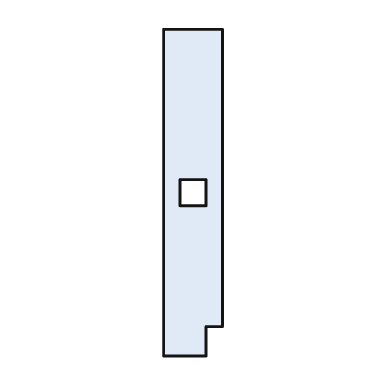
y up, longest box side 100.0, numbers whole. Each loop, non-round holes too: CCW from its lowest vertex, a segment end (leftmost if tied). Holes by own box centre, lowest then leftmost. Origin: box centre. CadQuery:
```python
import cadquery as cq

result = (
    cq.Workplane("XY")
    .moveTo(-9.0, -50.0)
    .lineTo(4.0, -50.0)
    .lineTo(4.0, -41.0)
    .lineTo(9.0, -41.0)
    .lineTo(9.0, 50.0)
    .lineTo(-9.0, 50.0)
    .close()
    .moveTo(-4.0, -4.0)
    .lineTo(4.0, -4.0)
    .lineTo(4.0, 4.0)
    .lineTo(-4.0, 4.0)
    .close()
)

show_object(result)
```